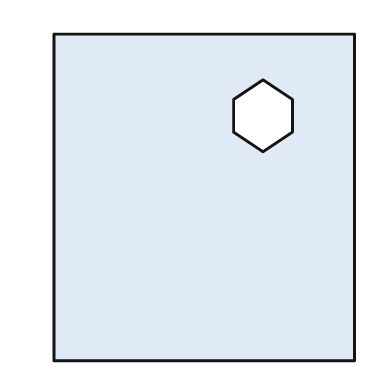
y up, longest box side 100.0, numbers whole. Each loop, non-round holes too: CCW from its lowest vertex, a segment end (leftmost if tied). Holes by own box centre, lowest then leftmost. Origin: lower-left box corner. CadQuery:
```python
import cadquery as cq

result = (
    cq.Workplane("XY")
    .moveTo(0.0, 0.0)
    .lineTo(92.0, 0.0)
    .lineTo(92.0, 100.0)
    .lineTo(0.0, 100.0)
    .close()
    .moveTo(64.0, 64.0)
    .lineTo(73.0, 70.0)
    .lineTo(73.0, 80.0)
    .lineTo(64.0, 86.0)
    .lineTo(55.0, 80.0)
    .lineTo(55.0, 70.0)
    .close()
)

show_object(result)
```